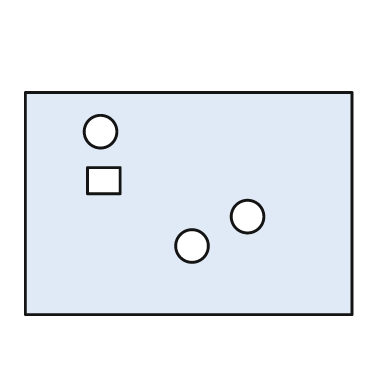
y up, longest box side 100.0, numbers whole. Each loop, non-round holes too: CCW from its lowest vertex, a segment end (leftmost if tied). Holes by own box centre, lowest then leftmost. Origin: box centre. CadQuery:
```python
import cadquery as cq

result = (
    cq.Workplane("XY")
    .moveTo(-50.0, -34.0)
    .lineTo(50.0, -34.0)
    .lineTo(50.0, 34.0)
    .lineTo(-50.0, 34.0)
    .close()
    .moveTo(1.0, -13.0)
    .circle(5.0)
    .moveTo(18.0, -4.0)
    .circle(5.0)
    .moveTo(-31.0, 3.0)
    .lineTo(-21.0, 3.0)
    .lineTo(-21.0, 11.0)
    .lineTo(-31.0, 11.0)
    .close()
    .moveTo(-27.0, 22.0)
    .circle(5.0)
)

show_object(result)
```